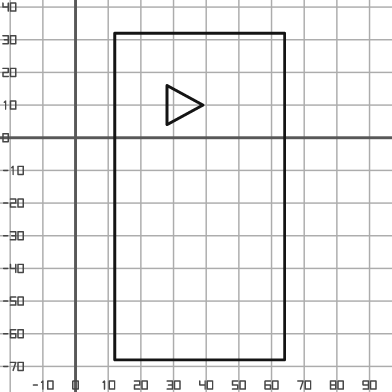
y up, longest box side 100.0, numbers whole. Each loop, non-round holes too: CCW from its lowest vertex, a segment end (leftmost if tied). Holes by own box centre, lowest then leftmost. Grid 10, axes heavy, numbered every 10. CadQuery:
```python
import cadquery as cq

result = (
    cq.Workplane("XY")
    .moveTo(12.0, -68.0)
    .lineTo(64.0, -68.0)
    .lineTo(64.0, 32.0)
    .lineTo(12.0, 32.0)
    .close()
    .moveTo(28.0, 4.0)
    .lineTo(39.0, 10.0)
    .lineTo(28.0, 16.0)
    .close()
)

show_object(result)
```